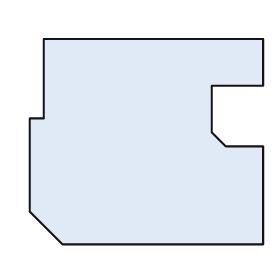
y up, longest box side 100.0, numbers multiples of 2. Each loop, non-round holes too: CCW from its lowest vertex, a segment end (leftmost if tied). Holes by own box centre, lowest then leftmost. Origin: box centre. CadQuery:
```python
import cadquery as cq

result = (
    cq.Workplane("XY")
    .moveTo(-36.0, -44.0)
    .lineTo(50.0, -44.0)
    .lineTo(50.0, -2.0)
    .lineTo(34.0, -2.0)
    .lineTo(28.0, 4.0)
    .lineTo(28.0, 24.0)
    .lineTo(50.0, 24.0)
    .lineTo(50.0, 44.0)
    .lineTo(-44.0, 44.0)
    .lineTo(-44.0, 10.0)
    .lineTo(-50.0, 10.0)
    .lineTo(-50.0, -30.0)
    .close()
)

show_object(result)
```